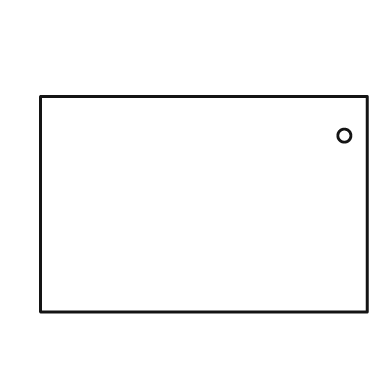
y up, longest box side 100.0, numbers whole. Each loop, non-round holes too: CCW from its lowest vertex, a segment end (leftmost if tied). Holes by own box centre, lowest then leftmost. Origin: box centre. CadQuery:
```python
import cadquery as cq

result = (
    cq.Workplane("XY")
    .moveTo(-50.0, -33.0)
    .lineTo(50.0, -33.0)
    .lineTo(50.0, 33.0)
    .lineTo(-50.0, 33.0)
    .close()
    .moveTo(43.0, 21.0)
    .circle(2.0)
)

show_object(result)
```